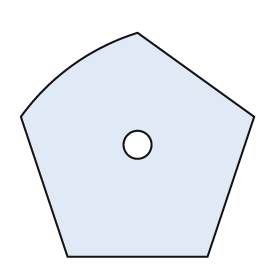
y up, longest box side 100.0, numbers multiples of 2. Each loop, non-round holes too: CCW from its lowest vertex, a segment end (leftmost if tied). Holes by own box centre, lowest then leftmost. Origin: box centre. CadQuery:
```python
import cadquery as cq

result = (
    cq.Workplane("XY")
    .moveTo(-30.0, -48.0)
    .lineTo(30.0, -48.0)
    .lineTo(50.0, 12.0)
    .lineTo(0.0, 48.0)
    .threePointArc((-28.0, 34.0), (-50.0, 12.0))
    .close()
    .moveTo(0.0, 0.0)
    .circle(6.0)
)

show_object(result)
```